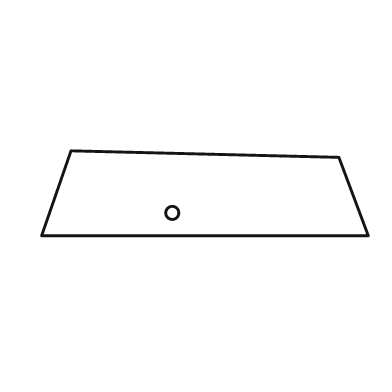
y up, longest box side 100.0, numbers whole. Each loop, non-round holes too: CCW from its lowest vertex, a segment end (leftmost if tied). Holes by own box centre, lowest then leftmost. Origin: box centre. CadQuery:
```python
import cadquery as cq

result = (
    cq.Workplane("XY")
    .moveTo(-50.0, -13.0)
    .lineTo(50.0, -13.0)
    .lineTo(41.0, 11.0)
    .lineTo(-41.0, 13.0)
    .close()
    .moveTo(-10.0, -6.0)
    .circle(2.0)
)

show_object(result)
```